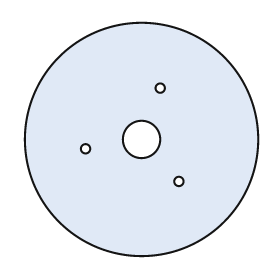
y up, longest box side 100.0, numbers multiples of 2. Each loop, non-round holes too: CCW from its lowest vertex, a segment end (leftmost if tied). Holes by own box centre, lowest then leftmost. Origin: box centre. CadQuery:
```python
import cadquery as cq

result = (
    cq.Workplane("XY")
    .moveTo(0.0, 0.0)
    .circle(50.0)
    .moveTo(16.0, -18.0)
    .circle(2.0)
    .moveTo(-24.0, -4.0)
    .circle(2.0)
    .moveTo(0.0, 0.0)
    .circle(8.0)
    .moveTo(8.0, 22.0)
    .circle(2.0)
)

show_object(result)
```